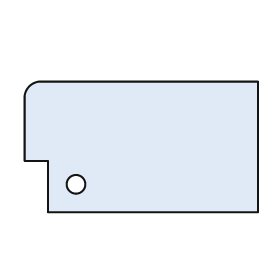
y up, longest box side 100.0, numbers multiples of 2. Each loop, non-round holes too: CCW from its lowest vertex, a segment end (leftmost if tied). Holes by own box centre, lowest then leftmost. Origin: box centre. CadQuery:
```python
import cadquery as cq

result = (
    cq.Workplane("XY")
    .moveTo(-40.0, -28.0)
    .lineTo(50.0, -28.0)
    .lineTo(50.0, 28.0)
    .lineTo(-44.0, 28.0)
    .threePointArc((-48.0, 26.0), (-50.0, 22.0))
    .lineTo(-50.0, -6.0)
    .lineTo(-40.0, -6.0)
    .close()
    .moveTo(-28.0, -16.0)
    .circle(4.0)
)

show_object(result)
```